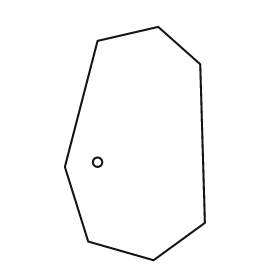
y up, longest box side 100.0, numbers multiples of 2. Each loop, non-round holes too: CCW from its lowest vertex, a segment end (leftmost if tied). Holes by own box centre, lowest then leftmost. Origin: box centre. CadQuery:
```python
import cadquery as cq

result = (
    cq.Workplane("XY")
    .moveTo(8.0, -50.0)
    .lineTo(30.0, -34.0)
    .lineTo(28.0, 34.0)
    .lineTo(10.0, 50.0)
    .lineTo(-16.0, 44.0)
    .lineTo(-30.0, -10.0)
    .lineTo(-20.0, -42.0)
    .close()
    .moveTo(-16.0, -8.0)
    .circle(2.0)
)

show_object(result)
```